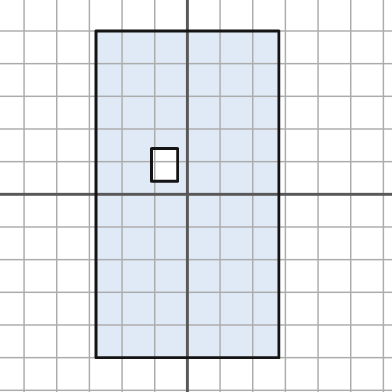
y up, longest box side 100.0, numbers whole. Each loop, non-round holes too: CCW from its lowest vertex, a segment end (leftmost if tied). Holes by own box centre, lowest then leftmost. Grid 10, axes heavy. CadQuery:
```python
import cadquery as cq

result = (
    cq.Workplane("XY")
    .moveTo(-28.0, -50.0)
    .lineTo(28.0, -50.0)
    .lineTo(28.0, 50.0)
    .lineTo(-28.0, 50.0)
    .close()
    .moveTo(-11.0, 4.0)
    .lineTo(-3.0, 4.0)
    .lineTo(-3.0, 14.0)
    .lineTo(-11.0, 14.0)
    .close()
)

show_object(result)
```